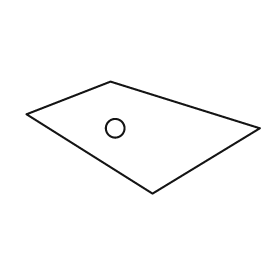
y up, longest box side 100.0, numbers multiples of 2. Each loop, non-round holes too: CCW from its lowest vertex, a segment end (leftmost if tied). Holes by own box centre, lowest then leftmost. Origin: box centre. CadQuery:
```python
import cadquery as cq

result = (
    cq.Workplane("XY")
    .moveTo(4.0, -24.0)
    .lineTo(50.0, 4.0)
    .lineTo(-14.0, 24.0)
    .lineTo(-50.0, 10.0)
    .close()
    .moveTo(-12.0, 4.0)
    .circle(4.0)
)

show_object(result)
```